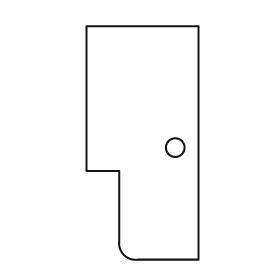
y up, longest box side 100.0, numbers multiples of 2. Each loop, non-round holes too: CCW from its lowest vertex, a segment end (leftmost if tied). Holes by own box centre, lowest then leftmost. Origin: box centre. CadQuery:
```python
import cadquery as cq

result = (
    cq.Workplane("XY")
    .moveTo(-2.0, -50.0)
    .lineTo(24.0, -50.0)
    .lineTo(24.0, 50.0)
    .lineTo(-24.0, 50.0)
    .lineTo(-24.0, -12.0)
    .lineTo(-10.0, -12.0)
    .lineTo(-10.0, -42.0)
    .threePointArc((-8.0, -48.0), (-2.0, -50.0))
    .close()
    .moveTo(14.0, -2.0)
    .circle(4.0)
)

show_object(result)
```